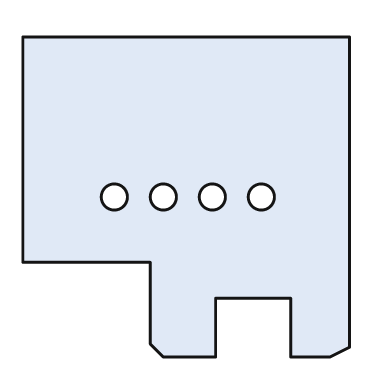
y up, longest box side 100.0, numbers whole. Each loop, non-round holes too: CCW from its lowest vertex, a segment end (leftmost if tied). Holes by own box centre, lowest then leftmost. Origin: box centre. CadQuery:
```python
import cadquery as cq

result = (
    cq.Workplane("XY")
    .moveTo(-7.0, -49.0)
    .lineTo(9.0, -49.0)
    .lineTo(9.0, -31.0)
    .lineTo(32.0, -31.0)
    .lineTo(32.0, -49.0)
    .lineTo(44.0, -49.0)
    .lineTo(50.0, -46.0)
    .lineTo(50.0, 49.0)
    .lineTo(-50.0, 49.0)
    .lineTo(-50.0, -20.0)
    .lineTo(-11.0, -20.0)
    .lineTo(-11.0, -45.0)
    .close()
    .moveTo(-22.0, 0.0)
    .circle(4.0)
    .moveTo(-7.0, 0.0)
    .circle(4.0)
    .moveTo(8.0, 0.0)
    .circle(4.0)
    .moveTo(23.0, 0.0)
    .circle(4.0)
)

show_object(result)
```